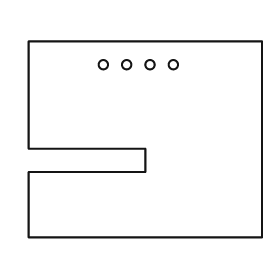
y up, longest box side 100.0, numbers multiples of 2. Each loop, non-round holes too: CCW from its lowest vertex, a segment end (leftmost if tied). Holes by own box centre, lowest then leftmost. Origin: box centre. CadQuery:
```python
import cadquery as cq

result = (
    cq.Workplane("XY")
    .moveTo(-50.0, -42.0)
    .lineTo(50.0, -42.0)
    .lineTo(50.0, 42.0)
    .lineTo(-50.0, 42.0)
    .lineTo(-50.0, -4.0)
    .lineTo(0.0, -4.0)
    .lineTo(0.0, -14.0)
    .lineTo(-50.0, -14.0)
    .close()
    .moveTo(-18.0, 32.0)
    .circle(2.0)
    .moveTo(-8.0, 32.0)
    .circle(2.0)
    .moveTo(2.0, 32.0)
    .circle(2.0)
    .moveTo(12.0, 32.0)
    .circle(2.0)
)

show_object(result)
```